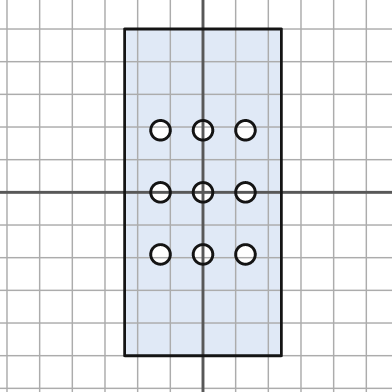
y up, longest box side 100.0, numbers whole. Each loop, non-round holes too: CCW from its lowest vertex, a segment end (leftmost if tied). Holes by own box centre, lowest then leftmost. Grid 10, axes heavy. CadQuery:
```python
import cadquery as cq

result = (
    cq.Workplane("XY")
    .moveTo(-24.0, -50.0)
    .lineTo(24.0, -50.0)
    .lineTo(24.0, 50.0)
    .lineTo(-24.0, 50.0)
    .close()
    .moveTo(-13.0, -19.0)
    .circle(3.0)
    .moveTo(0.0, -19.0)
    .circle(3.0)
    .moveTo(13.0, -19.0)
    .circle(3.0)
    .moveTo(-13.0, 0.0)
    .circle(3.0)
    .moveTo(0.0, 0.0)
    .circle(3.0)
    .moveTo(13.0, 0.0)
    .circle(3.0)
    .moveTo(-13.0, 19.0)
    .circle(3.0)
    .moveTo(0.0, 19.0)
    .circle(3.0)
    .moveTo(13.0, 19.0)
    .circle(3.0)
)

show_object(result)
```